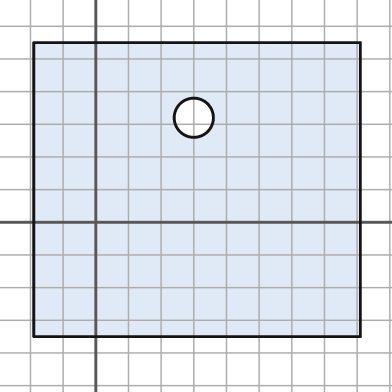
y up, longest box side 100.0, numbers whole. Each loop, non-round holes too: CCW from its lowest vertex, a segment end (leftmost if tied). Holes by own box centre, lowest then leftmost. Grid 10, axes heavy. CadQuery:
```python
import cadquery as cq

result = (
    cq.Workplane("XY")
    .moveTo(-19.0, -35.0)
    .lineTo(81.0, -35.0)
    .lineTo(81.0, 55.0)
    .lineTo(-19.0, 55.0)
    .close()
    .moveTo(30.0, 32.0)
    .circle(6.0)
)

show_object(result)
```